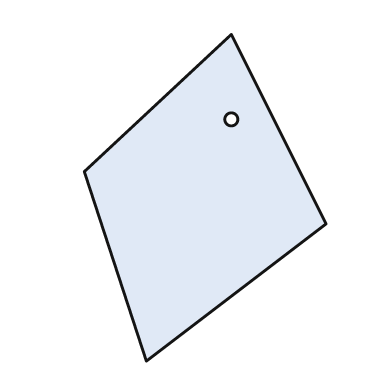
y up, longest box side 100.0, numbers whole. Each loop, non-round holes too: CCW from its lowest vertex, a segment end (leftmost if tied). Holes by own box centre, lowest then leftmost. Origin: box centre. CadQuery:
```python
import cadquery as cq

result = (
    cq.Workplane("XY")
    .moveTo(-18.0, -50.0)
    .lineTo(37.0, -8.0)
    .lineTo(8.0, 50.0)
    .lineTo(-37.0, 8.0)
    .close()
    .moveTo(8.0, 24.0)
    .circle(2.0)
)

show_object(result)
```